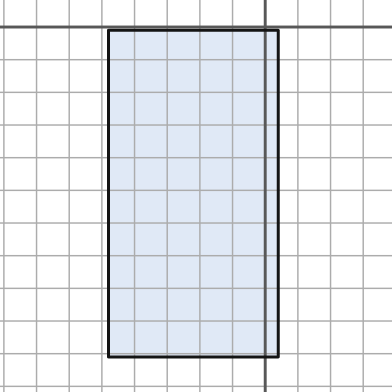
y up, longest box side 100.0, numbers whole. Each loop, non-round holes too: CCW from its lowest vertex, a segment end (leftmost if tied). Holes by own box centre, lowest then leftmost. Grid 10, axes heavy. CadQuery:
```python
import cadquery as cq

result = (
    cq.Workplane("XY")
    .moveTo(-48.0, -101.0)
    .lineTo(4.0, -101.0)
    .lineTo(4.0, -1.0)
    .lineTo(-48.0, -1.0)
    .close()
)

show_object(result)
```